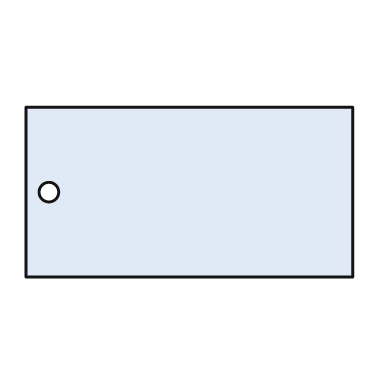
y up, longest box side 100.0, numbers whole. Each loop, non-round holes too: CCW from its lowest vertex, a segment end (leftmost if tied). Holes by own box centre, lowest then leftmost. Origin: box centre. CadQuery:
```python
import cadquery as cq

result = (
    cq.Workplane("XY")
    .moveTo(-50.0, -26.0)
    .lineTo(50.0, -26.0)
    .lineTo(50.0, 26.0)
    .lineTo(-50.0, 26.0)
    .close()
    .moveTo(-43.0, 0.0)
    .circle(3.0)
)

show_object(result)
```